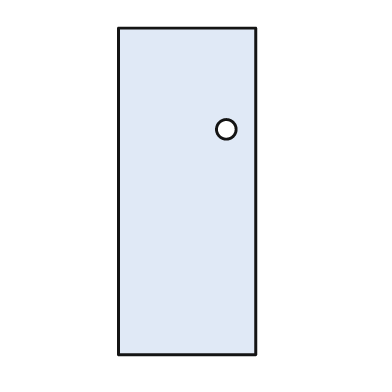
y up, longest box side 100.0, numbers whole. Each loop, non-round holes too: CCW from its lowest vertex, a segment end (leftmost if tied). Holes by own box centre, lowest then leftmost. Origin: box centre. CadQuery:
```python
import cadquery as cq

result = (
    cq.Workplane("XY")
    .moveTo(-21.0, -50.0)
    .lineTo(21.0, -50.0)
    .lineTo(21.0, 50.0)
    .lineTo(-21.0, 50.0)
    .close()
    .moveTo(12.0, 19.0)
    .circle(3.0)
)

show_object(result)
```